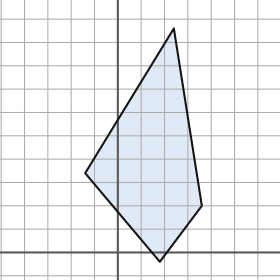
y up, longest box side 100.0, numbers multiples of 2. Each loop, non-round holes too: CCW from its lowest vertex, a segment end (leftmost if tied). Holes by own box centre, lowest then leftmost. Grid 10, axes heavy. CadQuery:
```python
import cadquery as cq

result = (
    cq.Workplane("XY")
    .moveTo(18.0, -4.0)
    .lineTo(36.0, 20.0)
    .lineTo(24.0, 96.0)
    .lineTo(-14.0, 34.0)
    .close()
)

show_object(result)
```